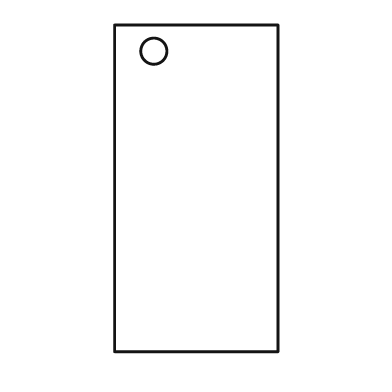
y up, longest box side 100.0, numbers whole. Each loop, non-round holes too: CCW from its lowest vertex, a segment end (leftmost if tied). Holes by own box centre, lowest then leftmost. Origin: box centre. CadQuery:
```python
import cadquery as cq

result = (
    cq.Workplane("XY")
    .moveTo(-25.0, -50.0)
    .lineTo(25.0, -50.0)
    .lineTo(25.0, 50.0)
    .lineTo(-25.0, 50.0)
    .close()
    .moveTo(-13.0, 42.0)
    .circle(4.0)
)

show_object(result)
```